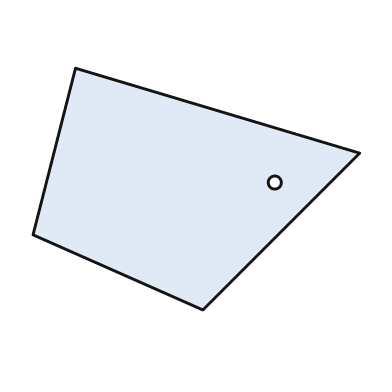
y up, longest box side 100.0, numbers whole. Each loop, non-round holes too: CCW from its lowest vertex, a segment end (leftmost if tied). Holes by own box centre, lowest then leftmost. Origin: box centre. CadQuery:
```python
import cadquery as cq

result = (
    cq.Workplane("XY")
    .moveTo(2.0, -37.0)
    .lineTo(50.0, 11.0)
    .lineTo(-37.0, 37.0)
    .lineTo(-50.0, -14.0)
    .close()
    .moveTo(24.0, 2.0)
    .circle(2.0)
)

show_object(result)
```